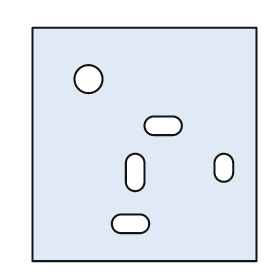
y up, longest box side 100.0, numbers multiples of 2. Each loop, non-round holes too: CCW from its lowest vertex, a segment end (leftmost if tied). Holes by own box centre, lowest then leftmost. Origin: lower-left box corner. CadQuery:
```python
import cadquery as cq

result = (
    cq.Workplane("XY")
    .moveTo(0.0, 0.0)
    .lineTo(96.0, 0.0)
    .lineTo(96.0, 100.0)
    .lineTo(0.0, 100.0)
    .close()
    .moveTo(38.0, 12.0)
    .lineTo(46.0, 12.0)
    .threePointArc((50.0, 16.0), (46.0, 20.0))
    .lineTo(38.0, 20.0)
    .threePointArc((34.0, 16.0), (38.0, 12.0))
    .close()
    .moveTo(40.0, 34.0)
    .threePointArc((44.0, 30.0), (48.0, 34.0))
    .lineTo(48.0, 42.0)
    .threePointArc((44.0, 46.0), (40.0, 42.0))
    .close()
    .moveTo(78.0, 38.0)
    .threePointArc((82.0, 34.0), (86.0, 38.0))
    .lineTo(86.0, 42.0)
    .threePointArc((82.0, 46.0), (78.0, 42.0))
    .close()
    .moveTo(52.0, 54.0)
    .lineTo(60.0, 54.0)
    .threePointArc((64.0, 58.0), (60.0, 62.0))
    .lineTo(52.0, 62.0)
    .threePointArc((48.0, 58.0), (52.0, 54.0))
    .close()
    .moveTo(24.0, 78.0)
    .circle(6.0)
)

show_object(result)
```